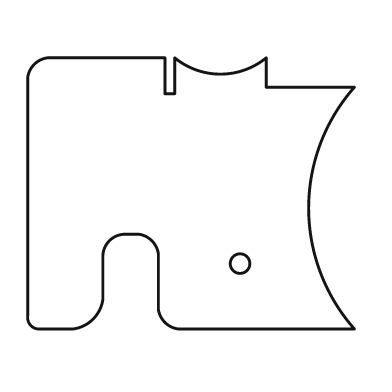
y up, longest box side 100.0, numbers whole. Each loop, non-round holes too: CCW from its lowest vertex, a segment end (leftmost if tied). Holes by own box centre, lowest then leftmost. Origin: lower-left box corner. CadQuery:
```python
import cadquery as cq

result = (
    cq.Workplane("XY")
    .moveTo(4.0, 0.0)
    .lineTo(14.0, 0.0)
    .threePointArc((20.0, 3.0), (23.0, 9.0))
    .lineTo(23.0, 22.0)
    .threePointArc((25.0, 27.0), (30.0, 29.0))
    .lineTo(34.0, 29.0)
    .threePointArc((38.0, 27.0), (40.0, 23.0))
    .lineTo(40.0, 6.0)
    .threePointArc((42.0, 2.0), (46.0, 0.0))
    .lineTo(100.0, 0.0)
    .threePointArc((86.0, 37.0), (100.0, 74.0))
    .lineTo(73.0, 74.0)
    .lineTo(73.0, 83.0)
    .threePointArc((59.0, 78.0), (45.0, 83.0))
    .lineTo(45.0, 72.0)
    .lineTo(42.0, 72.0)
    .lineTo(42.0, 83.0)
    .lineTo(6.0, 83.0)
    .threePointArc((2.0, 81.0), (0.0, 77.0))
    .lineTo(0.0, 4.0)
    .threePointArc((1.0, 1.0), (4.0, 0.0))
    .close()
    .moveTo(65.0, 20.0)
    .circle(3.0)
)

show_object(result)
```